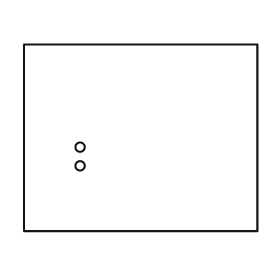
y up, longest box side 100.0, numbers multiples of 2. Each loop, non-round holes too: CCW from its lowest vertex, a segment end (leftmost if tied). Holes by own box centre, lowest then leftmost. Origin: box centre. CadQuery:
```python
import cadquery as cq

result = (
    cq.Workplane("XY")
    .moveTo(-50.0, -40.0)
    .lineTo(50.0, -40.0)
    .lineTo(50.0, 40.0)
    .lineTo(-50.0, 40.0)
    .close()
    .moveTo(-26.0, -12.0)
    .circle(2.0)
    .moveTo(-26.0, -4.0)
    .circle(2.0)
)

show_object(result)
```